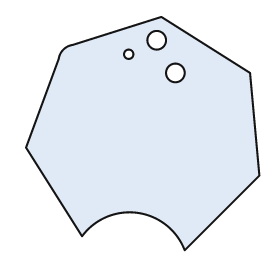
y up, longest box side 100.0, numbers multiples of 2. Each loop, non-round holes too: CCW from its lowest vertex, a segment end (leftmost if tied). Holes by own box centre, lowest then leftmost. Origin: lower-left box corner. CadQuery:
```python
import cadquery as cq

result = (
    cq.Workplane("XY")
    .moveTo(68.0, 0.0)
    .lineTo(100.0, 32.0)
    .lineTo(96.0, 76.0)
    .lineTo(58.0, 100.0)
    .lineTo(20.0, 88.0)
    .threePointArc((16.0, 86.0), (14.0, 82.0))
    .lineTo(0.0, 44.0)
    .lineTo(24.0, 6.0)
    .threePointArc((48.0, 16.0), (68.0, 0.0))
    .close()
    .moveTo(64.0, 76.0)
    .circle(4.0)
    .moveTo(44.0, 84.0)
    .circle(2.0)
    .moveTo(56.0, 90.0)
    .circle(4.0)
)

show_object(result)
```